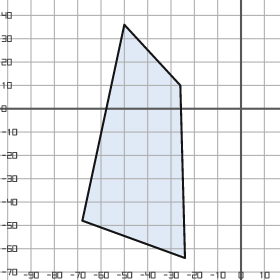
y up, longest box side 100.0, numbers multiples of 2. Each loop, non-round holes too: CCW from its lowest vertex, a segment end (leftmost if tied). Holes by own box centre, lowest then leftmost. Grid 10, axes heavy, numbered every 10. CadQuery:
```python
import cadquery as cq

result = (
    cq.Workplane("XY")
    .moveTo(-24.0, -64.0)
    .lineTo(-26.0, 10.0)
    .lineTo(-50.0, 36.0)
    .lineTo(-68.0, -48.0)
    .close()
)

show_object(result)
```